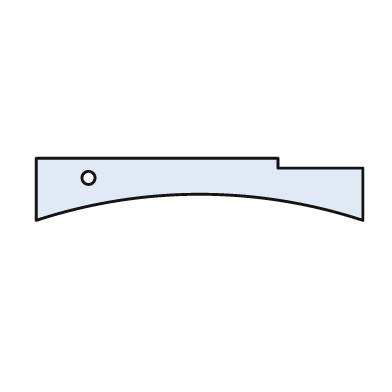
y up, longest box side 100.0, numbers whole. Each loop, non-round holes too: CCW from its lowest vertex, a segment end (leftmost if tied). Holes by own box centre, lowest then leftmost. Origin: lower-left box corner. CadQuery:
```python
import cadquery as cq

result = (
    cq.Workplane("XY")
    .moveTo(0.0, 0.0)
    .threePointArc((50.0, 8.0), (100.0, 0.0))
    .lineTo(100.0, 16.0)
    .lineTo(74.0, 16.0)
    .lineTo(74.0, 19.0)
    .lineTo(0.0, 19.0)
    .close()
    .moveTo(16.0, 13.0)
    .circle(2.0)
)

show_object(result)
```